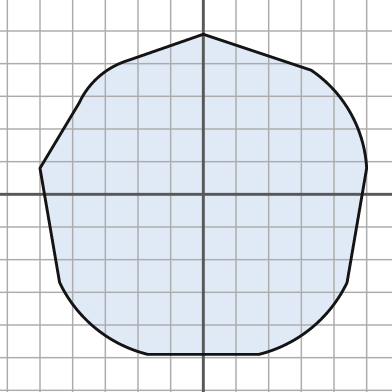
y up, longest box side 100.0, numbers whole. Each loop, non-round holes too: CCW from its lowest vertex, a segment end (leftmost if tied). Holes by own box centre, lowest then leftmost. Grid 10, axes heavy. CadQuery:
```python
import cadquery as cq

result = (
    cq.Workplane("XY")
    .moveTo(-17.0, -49.0)
    .lineTo(17.0, -49.0)
    .threePointArc((33.0, -41.0), (44.0, -27.0))
    .lineTo(50.0, 8.0)
    .threePointArc((45.0, 25.0), (33.0, 38.0))
    .lineTo(0.0, 49.0)
    .lineTo(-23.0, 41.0)
    .threePointArc((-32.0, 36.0), (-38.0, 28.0))
    .lineTo(-50.0, 8.0)
    .lineTo(-44.0, -27.0)
    .threePointArc((-33.0, -41.0), (-17.0, -49.0))
    .close()
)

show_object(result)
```